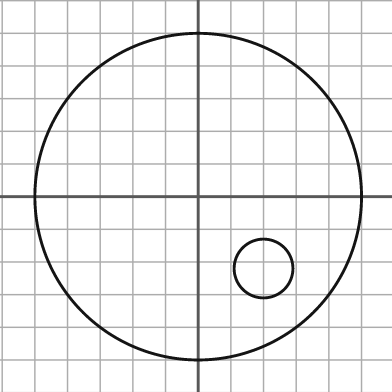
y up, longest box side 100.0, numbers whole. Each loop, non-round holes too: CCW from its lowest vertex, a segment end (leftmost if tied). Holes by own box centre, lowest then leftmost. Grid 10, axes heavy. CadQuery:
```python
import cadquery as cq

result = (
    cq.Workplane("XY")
    .moveTo(0.0, 0.0)
    .circle(50.0)
    .moveTo(20.0, -22.0)
    .circle(9.0)
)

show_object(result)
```